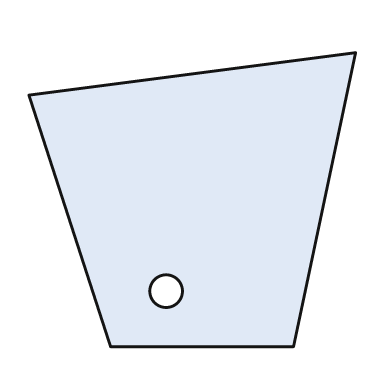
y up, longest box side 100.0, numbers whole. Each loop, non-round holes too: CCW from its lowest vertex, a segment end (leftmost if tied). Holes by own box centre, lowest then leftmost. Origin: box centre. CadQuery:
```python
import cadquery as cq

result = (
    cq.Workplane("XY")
    .moveTo(-25.0, -45.0)
    .lineTo(31.0, -45.0)
    .lineTo(50.0, 45.0)
    .lineTo(-50.0, 32.0)
    .close()
    .moveTo(-8.0, -28.0)
    .circle(5.0)
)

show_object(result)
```